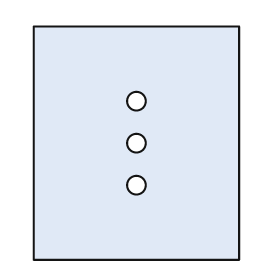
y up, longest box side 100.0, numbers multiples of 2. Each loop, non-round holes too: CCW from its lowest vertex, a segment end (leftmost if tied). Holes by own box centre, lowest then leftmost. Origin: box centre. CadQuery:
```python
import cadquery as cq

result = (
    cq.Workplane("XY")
    .moveTo(-44.0, -50.0)
    .lineTo(44.0, -50.0)
    .lineTo(44.0, 50.0)
    .lineTo(-44.0, 50.0)
    .close()
    .moveTo(0.0, -18.0)
    .circle(4.0)
    .moveTo(0.0, 0.0)
    .circle(4.0)
    .moveTo(0.0, 18.0)
    .circle(4.0)
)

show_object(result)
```